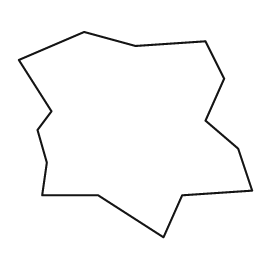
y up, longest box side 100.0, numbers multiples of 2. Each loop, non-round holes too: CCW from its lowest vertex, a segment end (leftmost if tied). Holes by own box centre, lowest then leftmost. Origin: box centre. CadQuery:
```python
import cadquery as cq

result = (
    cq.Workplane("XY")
    .moveTo(12.0, -44.0)
    .lineTo(20.0, -26.0)
    .lineTo(50.0, -24.0)
    .lineTo(44.0, -6.0)
    .lineTo(30.0, 6.0)
    .lineTo(38.0, 24.0)
    .lineTo(30.0, 40.0)
    .lineTo(0.0, 38.0)
    .lineTo(-22.0, 44.0)
    .lineTo(-50.0, 32.0)
    .lineTo(-36.0, 10.0)
    .lineTo(-42.0, 2.0)
    .lineTo(-38.0, -12.0)
    .lineTo(-40.0, -26.0)
    .lineTo(-16.0, -26.0)
    .close()
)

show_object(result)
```